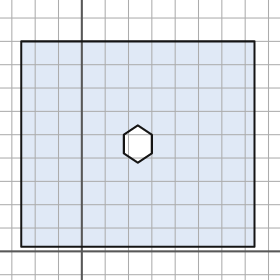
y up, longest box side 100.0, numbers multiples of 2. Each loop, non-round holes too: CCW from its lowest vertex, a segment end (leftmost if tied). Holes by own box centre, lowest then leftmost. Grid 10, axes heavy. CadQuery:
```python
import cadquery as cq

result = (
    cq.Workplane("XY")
    .moveTo(-26.0, 2.0)
    .lineTo(74.0, 2.0)
    .lineTo(74.0, 90.0)
    .lineTo(-26.0, 90.0)
    .close()
    .moveTo(24.0, 38.0)
    .lineTo(30.0, 42.0)
    .lineTo(30.0, 50.0)
    .lineTo(24.0, 54.0)
    .lineTo(18.0, 50.0)
    .lineTo(18.0, 42.0)
    .close()
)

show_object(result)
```